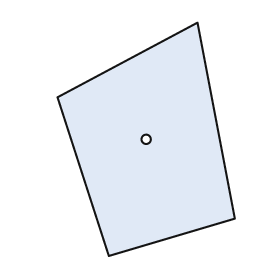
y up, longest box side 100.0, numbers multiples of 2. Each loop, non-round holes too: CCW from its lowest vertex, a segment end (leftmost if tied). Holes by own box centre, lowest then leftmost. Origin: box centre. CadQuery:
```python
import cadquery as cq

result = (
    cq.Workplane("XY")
    .moveTo(-16.0, -50.0)
    .lineTo(38.0, -34.0)
    .lineTo(22.0, 50.0)
    .lineTo(-38.0, 18.0)
    .close()
    .moveTo(0.0, 0.0)
    .circle(2.0)
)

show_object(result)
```